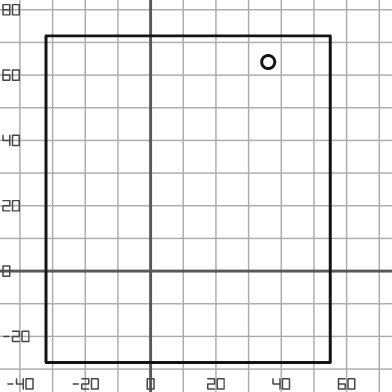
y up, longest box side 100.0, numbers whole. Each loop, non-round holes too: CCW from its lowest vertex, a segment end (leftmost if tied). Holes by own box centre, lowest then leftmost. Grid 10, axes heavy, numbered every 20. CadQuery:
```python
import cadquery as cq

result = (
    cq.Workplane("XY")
    .moveTo(-32.0, -28.0)
    .lineTo(55.0, -28.0)
    .lineTo(55.0, 72.0)
    .lineTo(-32.0, 72.0)
    .close()
    .moveTo(36.0, 64.0)
    .circle(2.0)
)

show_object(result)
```